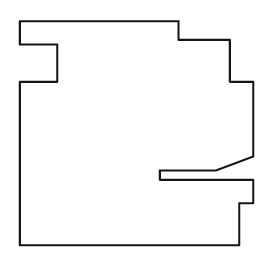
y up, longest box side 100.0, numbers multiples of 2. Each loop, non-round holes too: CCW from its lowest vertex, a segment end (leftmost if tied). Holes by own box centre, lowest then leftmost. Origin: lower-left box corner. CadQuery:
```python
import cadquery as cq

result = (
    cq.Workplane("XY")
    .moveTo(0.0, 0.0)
    .lineTo(94.0, 0.0)
    .lineTo(94.0, 18.0)
    .lineTo(100.0, 18.0)
    .lineTo(100.0, 28.0)
    .lineTo(60.0, 28.0)
    .lineTo(60.0, 32.0)
    .lineTo(84.0, 32.0)
    .lineTo(100.0, 38.0)
    .lineTo(100.0, 70.0)
    .lineTo(90.0, 70.0)
    .lineTo(90.0, 88.0)
    .lineTo(68.0, 88.0)
    .lineTo(68.0, 96.0)
    .lineTo(0.0, 96.0)
    .lineTo(0.0, 86.0)
    .lineTo(16.0, 86.0)
    .lineTo(16.0, 70.0)
    .lineTo(0.0, 70.0)
    .close()
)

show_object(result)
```